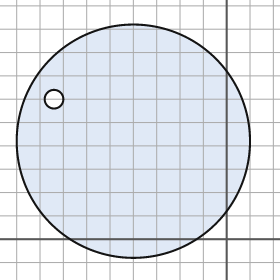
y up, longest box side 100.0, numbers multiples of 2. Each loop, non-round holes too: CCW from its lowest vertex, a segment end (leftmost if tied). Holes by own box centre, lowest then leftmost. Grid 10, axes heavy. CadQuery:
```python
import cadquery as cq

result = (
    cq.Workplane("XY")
    .moveTo(-40.0, 42.0)
    .circle(50.0)
    .moveTo(-74.0, 60.0)
    .circle(4.0)
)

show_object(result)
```